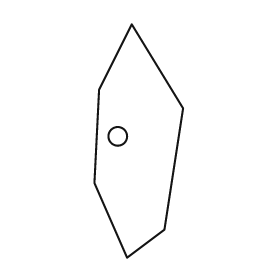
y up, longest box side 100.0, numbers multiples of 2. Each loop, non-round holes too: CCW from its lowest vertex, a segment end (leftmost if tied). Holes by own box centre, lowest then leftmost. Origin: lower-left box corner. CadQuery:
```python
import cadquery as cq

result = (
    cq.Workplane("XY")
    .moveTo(14.0, 0.0)
    .lineTo(30.0, 12.0)
    .lineTo(38.0, 64.0)
    .lineTo(16.0, 100.0)
    .lineTo(2.0, 72.0)
    .lineTo(0.0, 32.0)
    .close()
    .moveTo(10.0, 52.0)
    .circle(4.0)
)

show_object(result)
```